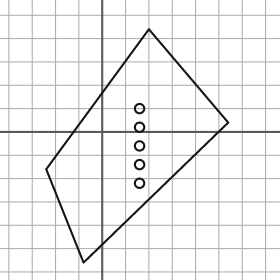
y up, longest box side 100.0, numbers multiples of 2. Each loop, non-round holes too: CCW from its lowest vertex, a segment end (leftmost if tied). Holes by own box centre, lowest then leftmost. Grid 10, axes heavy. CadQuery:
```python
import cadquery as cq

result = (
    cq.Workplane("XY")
    .moveTo(-8.0, -56.0)
    .lineTo(54.0, 4.0)
    .lineTo(20.0, 44.0)
    .lineTo(-24.0, -16.0)
    .close()
    .moveTo(16.0, -22.0)
    .circle(2.0)
    .moveTo(16.0, -14.0)
    .circle(2.0)
    .moveTo(16.0, -6.0)
    .circle(2.0)
    .moveTo(16.0, 2.0)
    .circle(2.0)
    .moveTo(16.0, 10.0)
    .circle(2.0)
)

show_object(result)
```